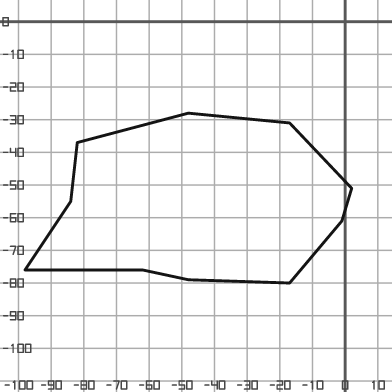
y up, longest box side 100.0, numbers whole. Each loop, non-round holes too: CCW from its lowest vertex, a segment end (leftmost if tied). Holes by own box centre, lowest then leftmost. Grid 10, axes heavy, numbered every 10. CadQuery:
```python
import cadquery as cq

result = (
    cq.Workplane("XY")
    .moveTo(-17.0, -80.0)
    .lineTo(-1.0, -61.0)
    .lineTo(2.0, -51.0)
    .lineTo(-17.0, -31.0)
    .lineTo(-48.0, -28.0)
    .lineTo(-82.0, -37.0)
    .lineTo(-84.0, -55.0)
    .lineTo(-98.0, -76.0)
    .lineTo(-62.0, -76.0)
    .lineTo(-48.0, -79.0)
    .close()
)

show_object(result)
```